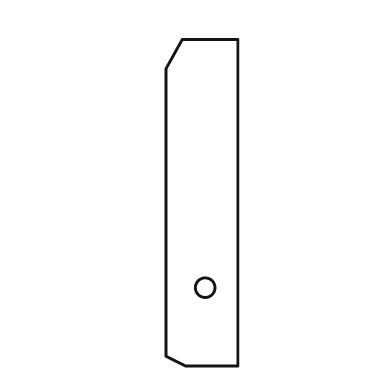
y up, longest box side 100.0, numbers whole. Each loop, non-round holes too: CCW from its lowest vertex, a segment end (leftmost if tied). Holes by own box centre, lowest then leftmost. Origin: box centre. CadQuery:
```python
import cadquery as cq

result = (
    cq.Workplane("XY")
    .moveTo(-5.0, -50.0)
    .lineTo(11.0, -50.0)
    .lineTo(11.0, 50.0)
    .lineTo(-6.0, 50.0)
    .lineTo(-11.0, 41.0)
    .lineTo(-11.0, -47.0)
    .close()
    .moveTo(1.0, -26.0)
    .circle(3.0)
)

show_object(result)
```